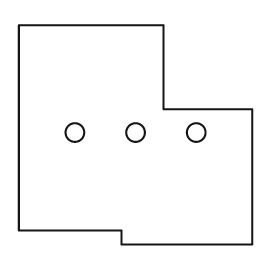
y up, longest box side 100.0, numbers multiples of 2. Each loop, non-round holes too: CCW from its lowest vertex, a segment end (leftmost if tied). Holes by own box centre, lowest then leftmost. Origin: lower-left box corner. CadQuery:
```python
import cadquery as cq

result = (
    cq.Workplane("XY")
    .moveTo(44.0, 0.0)
    .lineTo(100.0, 0.0)
    .lineTo(100.0, 58.0)
    .lineTo(62.0, 58.0)
    .lineTo(62.0, 94.0)
    .lineTo(0.0, 94.0)
    .lineTo(0.0, 6.0)
    .lineTo(44.0, 6.0)
    .close()
    .moveTo(24.0, 48.0)
    .circle(4.0)
    .moveTo(50.0, 48.0)
    .circle(4.0)
    .moveTo(76.0, 48.0)
    .circle(4.0)
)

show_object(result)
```